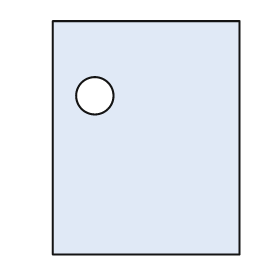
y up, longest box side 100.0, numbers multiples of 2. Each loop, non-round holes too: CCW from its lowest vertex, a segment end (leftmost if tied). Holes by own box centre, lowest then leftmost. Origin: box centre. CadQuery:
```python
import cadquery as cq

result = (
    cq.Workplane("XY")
    .moveTo(-40.0, -50.0)
    .lineTo(40.0, -50.0)
    .lineTo(40.0, 50.0)
    .lineTo(-40.0, 50.0)
    .close()
    .moveTo(-22.0, 18.0)
    .circle(8.0)
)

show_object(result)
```